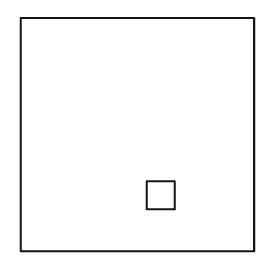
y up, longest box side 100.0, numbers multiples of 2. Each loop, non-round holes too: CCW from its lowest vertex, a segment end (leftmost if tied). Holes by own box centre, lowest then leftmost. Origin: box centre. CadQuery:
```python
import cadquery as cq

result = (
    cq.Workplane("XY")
    .moveTo(-50.0, -50.0)
    .lineTo(50.0, -50.0)
    .lineTo(50.0, 50.0)
    .lineTo(-50.0, 50.0)
    .close()
    .moveTo(4.0, -32.0)
    .lineTo(16.0, -32.0)
    .lineTo(16.0, -20.0)
    .lineTo(4.0, -20.0)
    .close()
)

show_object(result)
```